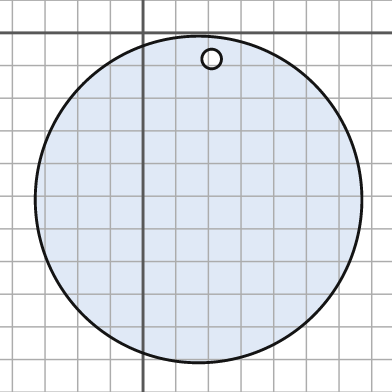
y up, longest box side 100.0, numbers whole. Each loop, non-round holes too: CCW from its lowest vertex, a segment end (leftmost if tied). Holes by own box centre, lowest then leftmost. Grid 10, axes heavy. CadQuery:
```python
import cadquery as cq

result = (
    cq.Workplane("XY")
    .moveTo(17.0, -51.0)
    .circle(50.0)
    .moveTo(21.0, -8.0)
    .circle(3.0)
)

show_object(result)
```